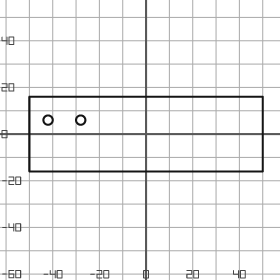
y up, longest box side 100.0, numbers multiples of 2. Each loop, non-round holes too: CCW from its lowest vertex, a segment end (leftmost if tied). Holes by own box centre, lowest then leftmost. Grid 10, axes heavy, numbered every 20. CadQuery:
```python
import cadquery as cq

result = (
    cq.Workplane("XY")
    .moveTo(-50.0, -16.0)
    .lineTo(50.0, -16.0)
    .lineTo(50.0, 16.0)
    .lineTo(-50.0, 16.0)
    .close()
    .moveTo(-42.0, 6.0)
    .circle(2.0)
    .moveTo(-28.0, 6.0)
    .circle(2.0)
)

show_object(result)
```